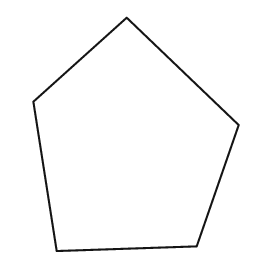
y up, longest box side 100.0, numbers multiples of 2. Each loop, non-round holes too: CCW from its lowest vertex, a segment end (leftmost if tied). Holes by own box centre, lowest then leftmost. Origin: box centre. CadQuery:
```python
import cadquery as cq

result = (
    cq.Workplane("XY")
    .moveTo(-34.0, -50.0)
    .lineTo(26.0, -48.0)
    .lineTo(44.0, 4.0)
    .lineTo(-4.0, 50.0)
    .lineTo(-44.0, 14.0)
    .close()
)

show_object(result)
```